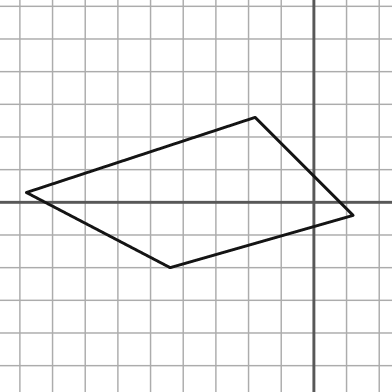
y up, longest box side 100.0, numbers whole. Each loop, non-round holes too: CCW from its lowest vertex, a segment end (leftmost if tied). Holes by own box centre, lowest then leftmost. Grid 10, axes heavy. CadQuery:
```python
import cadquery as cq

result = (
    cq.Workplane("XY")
    .moveTo(-44.0, -20.0)
    .lineTo(12.0, -4.0)
    .lineTo(-18.0, 26.0)
    .lineTo(-88.0, 3.0)
    .close()
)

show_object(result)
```